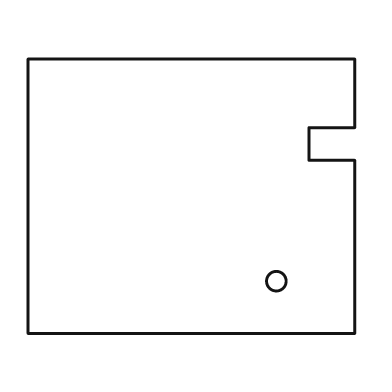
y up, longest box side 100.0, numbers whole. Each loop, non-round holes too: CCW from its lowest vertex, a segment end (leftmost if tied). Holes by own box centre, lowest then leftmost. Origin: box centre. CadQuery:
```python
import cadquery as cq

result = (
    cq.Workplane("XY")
    .moveTo(-50.0, -42.0)
    .lineTo(50.0, -42.0)
    .lineTo(50.0, 11.0)
    .lineTo(36.0, 11.0)
    .lineTo(36.0, 21.0)
    .lineTo(50.0, 21.0)
    .lineTo(50.0, 42.0)
    .lineTo(-50.0, 42.0)
    .close()
    .moveTo(26.0, -26.0)
    .circle(3.0)
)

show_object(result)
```